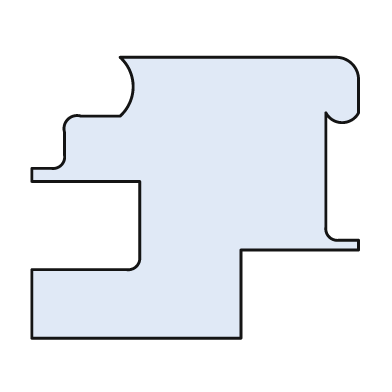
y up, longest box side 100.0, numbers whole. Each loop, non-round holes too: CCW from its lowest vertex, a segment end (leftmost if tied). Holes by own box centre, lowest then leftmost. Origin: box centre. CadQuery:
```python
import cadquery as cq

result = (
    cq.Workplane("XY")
    .moveTo(-50.0, -43.0)
    .lineTo(14.0, -43.0)
    .lineTo(14.0, -16.0)
    .lineTo(50.0, -16.0)
    .lineTo(50.0, -13.0)
    .lineTo(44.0, -13.0)
    .threePointArc((41.0, -12.0), (40.0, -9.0))
    .lineTo(40.0, 26.0)
    .threePointArc((45.0, 23.0), (50.0, 26.0))
    .lineTo(50.0, 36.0)
    .threePointArc((48.0, 41.0), (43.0, 43.0))
    .lineTo(-23.0, 43.0)
    .threePointArc((-19.0, 34.0), (-23.0, 25.0))
    .lineTo(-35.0, 25.0)
    .threePointArc((-39.0, 24.0), (-40.0, 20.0))
    .lineTo(-40.0, 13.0)
    .threePointArc((-41.0, 10.0), (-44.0, 9.0))
    .lineTo(-50.0, 9.0)
    .lineTo(-50.0, 5.0)
    .lineTo(-17.0, 5.0)
    .lineTo(-17.0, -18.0)
    .threePointArc((-18.0, -21.0), (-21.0, -22.0))
    .lineTo(-50.0, -22.0)
    .close()
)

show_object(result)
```